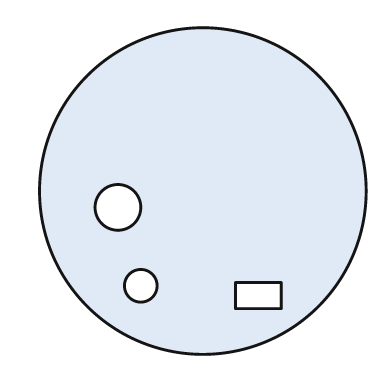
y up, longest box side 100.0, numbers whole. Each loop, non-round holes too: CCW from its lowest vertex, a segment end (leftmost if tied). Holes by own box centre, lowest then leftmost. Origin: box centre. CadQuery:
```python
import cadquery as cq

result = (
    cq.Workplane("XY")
    .moveTo(0.0, 0.0)
    .circle(50.0)
    .moveTo(10.0, -36.0)
    .lineTo(24.0, -36.0)
    .lineTo(24.0, -28.0)
    .lineTo(10.0, -28.0)
    .close()
    .moveTo(-19.0, -29.0)
    .circle(5.0)
    .moveTo(-26.0, -5.0)
    .circle(7.0)
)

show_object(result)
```